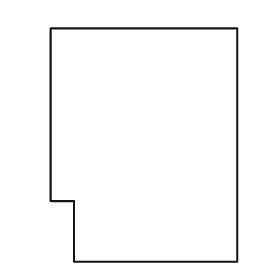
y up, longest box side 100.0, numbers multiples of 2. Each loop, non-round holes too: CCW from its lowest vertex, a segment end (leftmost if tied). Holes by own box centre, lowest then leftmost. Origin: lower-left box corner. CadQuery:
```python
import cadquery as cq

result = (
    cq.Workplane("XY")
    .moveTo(10.0, 0.0)
    .lineTo(80.0, 0.0)
    .lineTo(80.0, 100.0)
    .lineTo(0.0, 100.0)
    .lineTo(0.0, 26.0)
    .lineTo(10.0, 26.0)
    .close()
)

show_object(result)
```